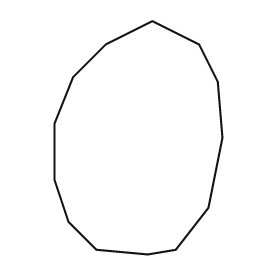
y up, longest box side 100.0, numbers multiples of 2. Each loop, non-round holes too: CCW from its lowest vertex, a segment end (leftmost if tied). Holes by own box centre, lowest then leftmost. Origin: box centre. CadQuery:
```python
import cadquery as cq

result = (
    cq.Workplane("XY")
    .moveTo(4.0, -50.0)
    .lineTo(16.0, -48.0)
    .lineTo(30.0, -30.0)
    .lineTo(36.0, 0.0)
    .lineTo(34.0, 24.0)
    .lineTo(26.0, 40.0)
    .lineTo(6.0, 50.0)
    .lineTo(-14.0, 40.0)
    .lineTo(-28.0, 26.0)
    .lineTo(-36.0, 6.0)
    .lineTo(-36.0, -18.0)
    .lineTo(-30.0, -36.0)
    .lineTo(-18.0, -48.0)
    .close()
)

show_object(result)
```